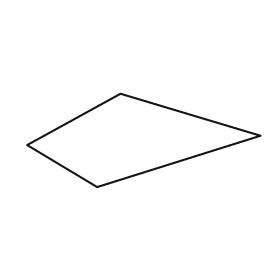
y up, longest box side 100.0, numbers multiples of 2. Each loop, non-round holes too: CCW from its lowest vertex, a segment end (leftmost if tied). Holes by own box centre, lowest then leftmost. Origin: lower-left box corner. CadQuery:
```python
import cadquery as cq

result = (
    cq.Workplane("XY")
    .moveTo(30.0, 0.0)
    .lineTo(100.0, 22.0)
    .lineTo(40.0, 40.0)
    .lineTo(0.0, 18.0)
    .close()
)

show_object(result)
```